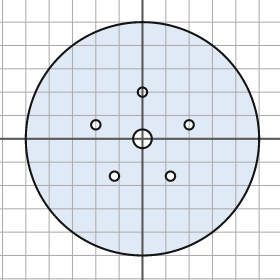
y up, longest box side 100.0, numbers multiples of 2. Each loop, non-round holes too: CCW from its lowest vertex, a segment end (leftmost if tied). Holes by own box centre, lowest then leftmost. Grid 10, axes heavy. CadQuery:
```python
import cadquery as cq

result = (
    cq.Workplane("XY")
    .moveTo(0.0, 0.0)
    .circle(50.0)
    .moveTo(-12.0, -16.0)
    .circle(2.0)
    .moveTo(12.0, -16.0)
    .circle(2.0)
    .moveTo(0.0, 0.0)
    .circle(4.0)
    .moveTo(-20.0, 6.0)
    .circle(2.0)
    .moveTo(20.0, 6.0)
    .circle(2.0)
    .moveTo(0.0, 20.0)
    .circle(2.0)
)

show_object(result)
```